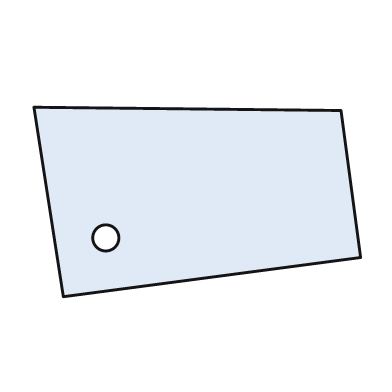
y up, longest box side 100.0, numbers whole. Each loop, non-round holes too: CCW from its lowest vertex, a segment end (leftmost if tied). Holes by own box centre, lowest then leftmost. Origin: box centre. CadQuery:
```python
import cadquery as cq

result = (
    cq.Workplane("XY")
    .moveTo(-41.0, -29.0)
    .lineTo(50.0, -17.0)
    .lineTo(44.0, 28.0)
    .lineTo(-50.0, 29.0)
    .close()
    .moveTo(-28.0, -11.0)
    .circle(4.0)
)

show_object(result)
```